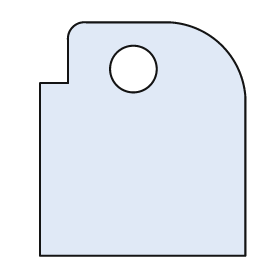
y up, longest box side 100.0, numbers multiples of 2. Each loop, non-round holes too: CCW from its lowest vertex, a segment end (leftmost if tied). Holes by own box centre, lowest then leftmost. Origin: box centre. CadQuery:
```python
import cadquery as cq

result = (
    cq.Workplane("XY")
    .moveTo(-44.0, -50.0)
    .lineTo(44.0, -50.0)
    .lineTo(44.0, 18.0)
    .threePointArc((34.0, 40.0), (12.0, 50.0))
    .lineTo(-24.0, 50.0)
    .threePointArc((-30.0, 48.0), (-32.0, 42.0))
    .lineTo(-32.0, 24.0)
    .lineTo(-44.0, 24.0)
    .close()
    .moveTo(-4.0, 30.0)
    .circle(10.0)
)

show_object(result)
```